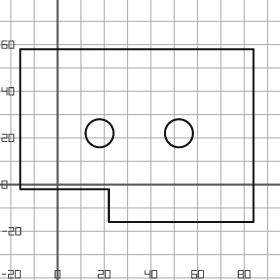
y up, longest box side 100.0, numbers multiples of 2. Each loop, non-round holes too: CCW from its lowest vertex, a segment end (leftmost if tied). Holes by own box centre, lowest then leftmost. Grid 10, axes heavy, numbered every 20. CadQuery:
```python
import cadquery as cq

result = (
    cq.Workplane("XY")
    .moveTo(22.0, -16.0)
    .lineTo(84.0, -16.0)
    .lineTo(84.0, 58.0)
    .lineTo(-16.0, 58.0)
    .lineTo(-16.0, -2.0)
    .lineTo(22.0, -2.0)
    .close()
    .moveTo(18.0, 22.0)
    .circle(6.0)
    .moveTo(52.0, 22.0)
    .circle(6.0)
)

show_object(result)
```